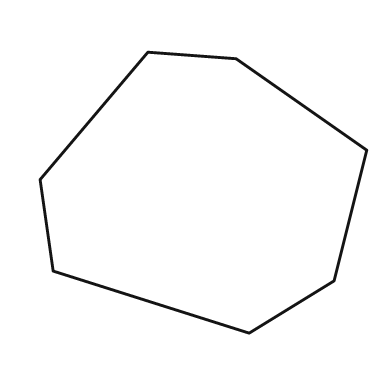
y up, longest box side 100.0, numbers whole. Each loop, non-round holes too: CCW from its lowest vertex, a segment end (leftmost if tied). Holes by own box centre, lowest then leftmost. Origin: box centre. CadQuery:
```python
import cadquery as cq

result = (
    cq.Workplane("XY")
    .moveTo(14.0, -43.0)
    .lineTo(40.0, -27.0)
    .lineTo(50.0, 13.0)
    .lineTo(10.0, 41.0)
    .lineTo(-17.0, 43.0)
    .lineTo(-50.0, 4.0)
    .lineTo(-46.0, -24.0)
    .close()
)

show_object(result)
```